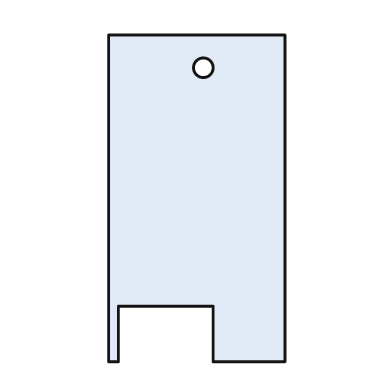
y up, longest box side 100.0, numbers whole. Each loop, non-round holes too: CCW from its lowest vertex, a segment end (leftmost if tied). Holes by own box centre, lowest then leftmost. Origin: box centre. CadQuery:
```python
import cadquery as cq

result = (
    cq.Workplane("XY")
    .moveTo(-27.0, -50.0)
    .lineTo(-24.0, -50.0)
    .lineTo(-24.0, -33.0)
    .lineTo(5.0, -33.0)
    .lineTo(5.0, -50.0)
    .lineTo(27.0, -50.0)
    .lineTo(27.0, 50.0)
    .lineTo(-27.0, 50.0)
    .close()
    .moveTo(2.0, 40.0)
    .circle(3.0)
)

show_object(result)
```